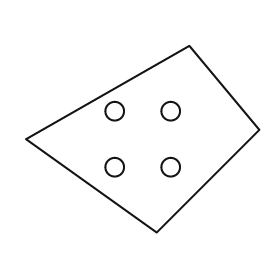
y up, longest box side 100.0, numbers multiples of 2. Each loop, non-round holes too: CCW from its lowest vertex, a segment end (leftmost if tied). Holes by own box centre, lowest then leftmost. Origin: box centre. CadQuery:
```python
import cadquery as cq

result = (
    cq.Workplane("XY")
    .moveTo(6.0, -40.0)
    .lineTo(50.0, 4.0)
    .lineTo(20.0, 40.0)
    .lineTo(-50.0, 0.0)
    .close()
    .moveTo(-12.0, -12.0)
    .circle(4.0)
    .moveTo(12.0, -12.0)
    .circle(4.0)
    .moveTo(-12.0, 12.0)
    .circle(4.0)
    .moveTo(12.0, 12.0)
    .circle(4.0)
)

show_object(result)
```